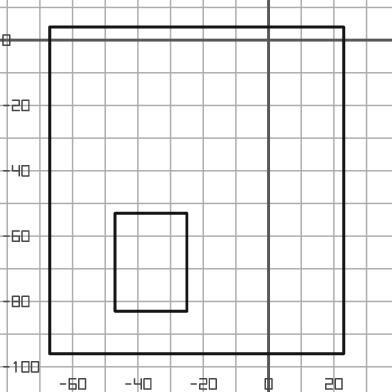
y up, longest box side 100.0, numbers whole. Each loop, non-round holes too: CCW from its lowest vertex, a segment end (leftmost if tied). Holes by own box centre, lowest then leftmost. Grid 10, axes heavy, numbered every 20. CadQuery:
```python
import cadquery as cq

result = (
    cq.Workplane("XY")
    .moveTo(-67.0, -96.0)
    .lineTo(23.0, -96.0)
    .lineTo(23.0, 4.0)
    .lineTo(-67.0, 4.0)
    .close()
    .moveTo(-47.0, -83.0)
    .lineTo(-25.0, -83.0)
    .lineTo(-25.0, -53.0)
    .lineTo(-47.0, -53.0)
    .close()
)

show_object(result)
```